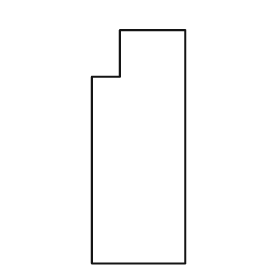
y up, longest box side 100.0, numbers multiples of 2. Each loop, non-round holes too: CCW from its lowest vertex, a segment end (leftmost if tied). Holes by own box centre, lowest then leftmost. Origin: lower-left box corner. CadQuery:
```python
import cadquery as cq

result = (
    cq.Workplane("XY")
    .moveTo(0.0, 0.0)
    .lineTo(40.0, 0.0)
    .lineTo(40.0, 100.0)
    .lineTo(12.0, 100.0)
    .lineTo(12.0, 80.0)
    .lineTo(0.0, 80.0)
    .close()
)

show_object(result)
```